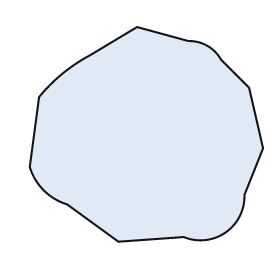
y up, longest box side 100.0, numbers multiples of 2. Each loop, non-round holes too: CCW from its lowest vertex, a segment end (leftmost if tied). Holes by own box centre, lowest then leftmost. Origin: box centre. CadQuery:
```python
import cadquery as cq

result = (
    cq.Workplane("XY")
    .moveTo(-12.0, -46.0)
    .lineTo(16.0, -44.0)
    .threePointArc((34.0, -42.0), (42.0, -26.0))
    .lineTo(50.0, -6.0)
    .lineTo(44.0, 20.0)
    .lineTo(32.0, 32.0)
    .threePointArc((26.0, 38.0), (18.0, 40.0))
    .lineTo(-4.0, 46.0)
    .lineTo(-24.0, 34.0)
    .threePointArc((-36.0, 26.0), (-46.0, 16.0))
    .lineTo(-50.0, -14.0)
    .threePointArc((-44.0, -24.0), (-34.0, -30.0))
    .close()
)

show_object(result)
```